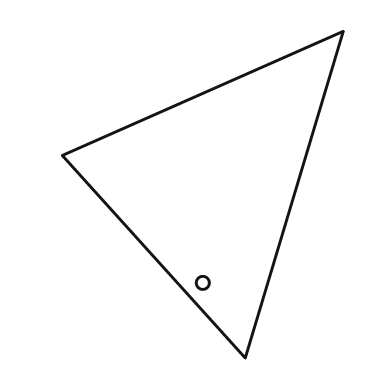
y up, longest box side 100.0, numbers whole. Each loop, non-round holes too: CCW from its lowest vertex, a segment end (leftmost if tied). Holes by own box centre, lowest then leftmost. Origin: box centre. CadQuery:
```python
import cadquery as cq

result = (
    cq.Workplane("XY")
    .moveTo(13.0, -50.0)
    .lineTo(43.0, 50.0)
    .lineTo(-43.0, 12.0)
    .close()
    .moveTo(0.0, -27.0)
    .circle(2.0)
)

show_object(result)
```